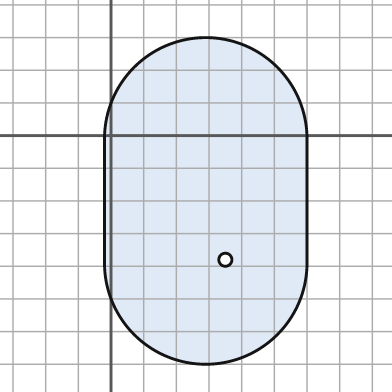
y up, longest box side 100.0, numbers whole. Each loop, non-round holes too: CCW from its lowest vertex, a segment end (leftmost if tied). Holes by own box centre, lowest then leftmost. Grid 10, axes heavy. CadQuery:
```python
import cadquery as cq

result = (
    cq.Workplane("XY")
    .moveTo(-2.0, -39.0)
    .threePointArc((29.0, -70.0), (60.0, -39.0))
    .lineTo(60.0, -1.0)
    .threePointArc((29.0, 30.0), (-2.0, -1.0))
    .close()
    .moveTo(35.0, -38.0)
    .circle(2.0)
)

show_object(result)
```